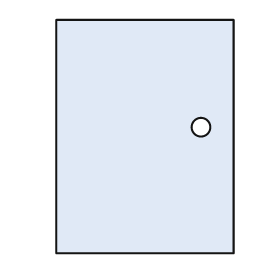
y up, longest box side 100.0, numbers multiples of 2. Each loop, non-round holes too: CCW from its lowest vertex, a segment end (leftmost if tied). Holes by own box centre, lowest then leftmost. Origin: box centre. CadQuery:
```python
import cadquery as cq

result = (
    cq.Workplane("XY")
    .moveTo(-38.0, -50.0)
    .lineTo(38.0, -50.0)
    .lineTo(38.0, 50.0)
    .lineTo(-38.0, 50.0)
    .close()
    .moveTo(24.0, 4.0)
    .circle(4.0)
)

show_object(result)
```